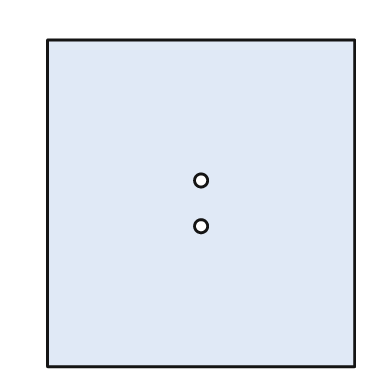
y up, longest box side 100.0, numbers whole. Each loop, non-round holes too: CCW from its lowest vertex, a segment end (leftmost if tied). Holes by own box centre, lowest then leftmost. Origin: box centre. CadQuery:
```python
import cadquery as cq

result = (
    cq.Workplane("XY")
    .moveTo(-47.0, -50.0)
    .lineTo(47.0, -50.0)
    .lineTo(47.0, 50.0)
    .lineTo(-47.0, 50.0)
    .close()
    .moveTo(0.0, -7.0)
    .circle(2.0)
    .moveTo(0.0, 7.0)
    .circle(2.0)
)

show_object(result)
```